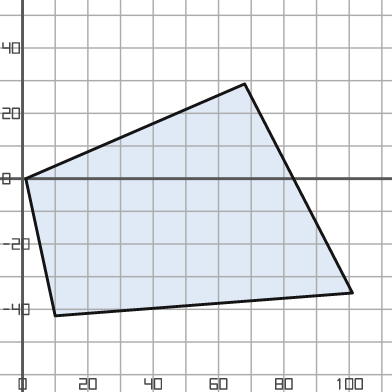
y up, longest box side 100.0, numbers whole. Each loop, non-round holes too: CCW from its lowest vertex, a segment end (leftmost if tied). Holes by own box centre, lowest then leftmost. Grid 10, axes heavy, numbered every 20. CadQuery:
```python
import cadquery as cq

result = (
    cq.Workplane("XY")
    .moveTo(10.0, -42.0)
    .lineTo(101.0, -35.0)
    .lineTo(68.0, 29.0)
    .lineTo(1.0, 0.0)
    .close()
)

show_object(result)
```